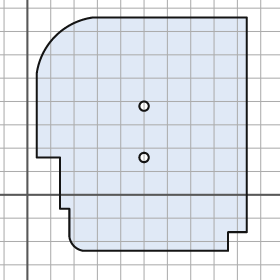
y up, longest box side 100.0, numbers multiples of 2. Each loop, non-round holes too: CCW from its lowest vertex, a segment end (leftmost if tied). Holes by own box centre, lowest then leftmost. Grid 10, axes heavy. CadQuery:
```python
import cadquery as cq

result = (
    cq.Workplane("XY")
    .moveTo(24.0, -24.0)
    .lineTo(86.0, -24.0)
    .lineTo(86.0, -16.0)
    .lineTo(94.0, -16.0)
    .lineTo(94.0, 76.0)
    .lineTo(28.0, 76.0)
    .threePointArc((12.0, 68.0), (4.0, 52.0))
    .lineTo(4.0, 16.0)
    .lineTo(14.0, 16.0)
    .lineTo(14.0, -6.0)
    .lineTo(18.0, -6.0)
    .lineTo(18.0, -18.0)
    .threePointArc((20.0, -22.0), (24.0, -24.0))
    .close()
    .moveTo(50.0, 16.0)
    .circle(2.0)
    .moveTo(50.0, 38.0)
    .circle(2.0)
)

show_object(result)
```